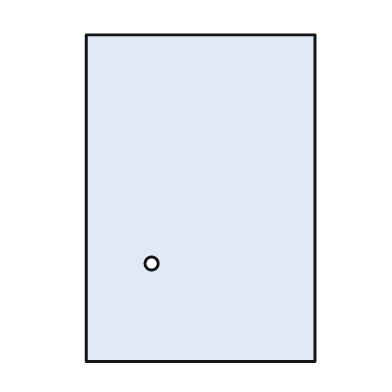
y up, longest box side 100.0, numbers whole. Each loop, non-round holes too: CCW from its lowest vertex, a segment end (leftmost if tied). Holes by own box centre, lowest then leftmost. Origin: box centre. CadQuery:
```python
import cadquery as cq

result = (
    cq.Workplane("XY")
    .moveTo(-35.0, -50.0)
    .lineTo(35.0, -50.0)
    .lineTo(35.0, 50.0)
    .lineTo(-35.0, 50.0)
    .close()
    .moveTo(-15.0, -20.0)
    .circle(2.0)
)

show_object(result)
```